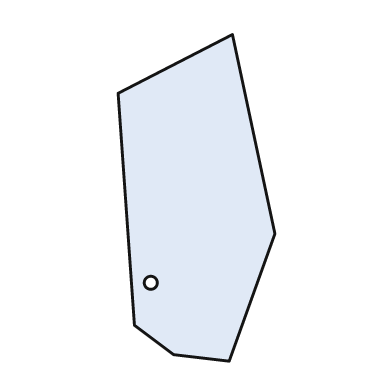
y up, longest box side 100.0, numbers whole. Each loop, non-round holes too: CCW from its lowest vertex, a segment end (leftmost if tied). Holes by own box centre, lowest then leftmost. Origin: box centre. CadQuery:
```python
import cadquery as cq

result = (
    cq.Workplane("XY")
    .moveTo(10.0, -50.0)
    .lineTo(24.0, -11.0)
    .lineTo(11.0, 50.0)
    .lineTo(-24.0, 32.0)
    .lineTo(-19.0, -39.0)
    .lineTo(-7.0, -48.0)
    .close()
    .moveTo(-14.0, -26.0)
    .circle(2.0)
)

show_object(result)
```